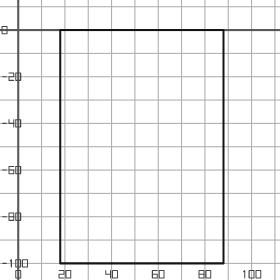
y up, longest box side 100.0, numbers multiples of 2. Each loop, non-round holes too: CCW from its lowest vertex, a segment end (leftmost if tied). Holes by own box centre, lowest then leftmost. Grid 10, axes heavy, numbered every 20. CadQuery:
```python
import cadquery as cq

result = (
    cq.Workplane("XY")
    .moveTo(18.0, -100.0)
    .lineTo(88.0, -100.0)
    .lineTo(88.0, 0.0)
    .lineTo(18.0, 0.0)
    .close()
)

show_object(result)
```